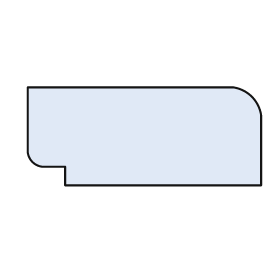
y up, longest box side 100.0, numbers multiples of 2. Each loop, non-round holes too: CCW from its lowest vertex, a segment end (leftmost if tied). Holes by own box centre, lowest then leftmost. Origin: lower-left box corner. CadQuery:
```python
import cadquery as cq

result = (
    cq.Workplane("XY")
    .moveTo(16.0, 0.0)
    .lineTo(100.0, 0.0)
    .lineTo(100.0, 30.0)
    .threePointArc((96.0, 38.0), (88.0, 42.0))
    .lineTo(0.0, 42.0)
    .lineTo(0.0, 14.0)
    .threePointArc((2.0, 10.0), (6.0, 8.0))
    .lineTo(16.0, 8.0)
    .close()
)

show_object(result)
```